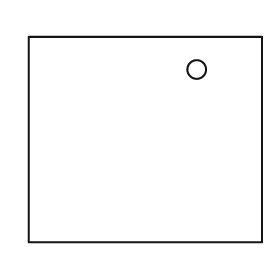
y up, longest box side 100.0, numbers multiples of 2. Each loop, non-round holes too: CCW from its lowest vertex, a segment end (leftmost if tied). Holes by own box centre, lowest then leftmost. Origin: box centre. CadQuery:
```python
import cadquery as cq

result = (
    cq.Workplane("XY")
    .moveTo(-50.0, -44.0)
    .lineTo(50.0, -44.0)
    .lineTo(50.0, 44.0)
    .lineTo(-50.0, 44.0)
    .close()
    .moveTo(22.0, 30.0)
    .circle(4.0)
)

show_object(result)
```